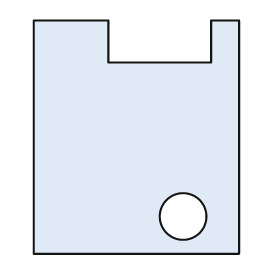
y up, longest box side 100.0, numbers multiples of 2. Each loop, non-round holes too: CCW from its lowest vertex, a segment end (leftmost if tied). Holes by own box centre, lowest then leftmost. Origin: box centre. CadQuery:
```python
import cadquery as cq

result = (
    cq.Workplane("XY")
    .moveTo(-44.0, -50.0)
    .lineTo(44.0, -50.0)
    .lineTo(44.0, 50.0)
    .lineTo(32.0, 50.0)
    .lineTo(32.0, 32.0)
    .lineTo(-12.0, 32.0)
    .lineTo(-12.0, 50.0)
    .lineTo(-44.0, 50.0)
    .close()
    .moveTo(20.0, -34.0)
    .circle(10.0)
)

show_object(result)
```